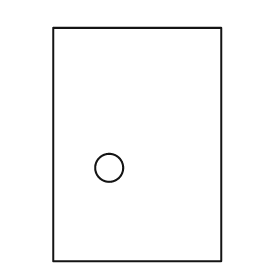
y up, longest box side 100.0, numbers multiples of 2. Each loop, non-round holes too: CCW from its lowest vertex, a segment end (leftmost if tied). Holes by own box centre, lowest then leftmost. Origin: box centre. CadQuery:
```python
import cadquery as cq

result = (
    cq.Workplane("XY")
    .moveTo(-36.0, -50.0)
    .lineTo(36.0, -50.0)
    .lineTo(36.0, 50.0)
    .lineTo(-36.0, 50.0)
    .close()
    .moveTo(-12.0, -10.0)
    .circle(6.0)
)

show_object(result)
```